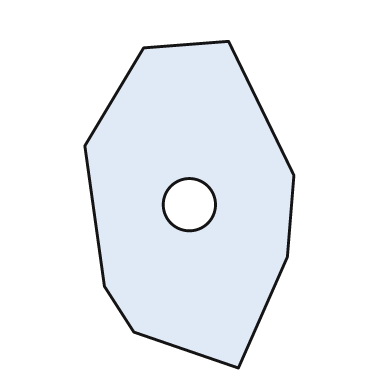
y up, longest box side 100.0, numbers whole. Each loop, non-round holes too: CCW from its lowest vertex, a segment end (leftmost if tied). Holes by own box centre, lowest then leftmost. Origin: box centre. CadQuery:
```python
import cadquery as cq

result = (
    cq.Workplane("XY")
    .moveTo(15.0, -50.0)
    .lineTo(30.0, -16.0)
    .lineTo(32.0, 9.0)
    .lineTo(12.0, 50.0)
    .lineTo(-14.0, 48.0)
    .lineTo(-32.0, 18.0)
    .lineTo(-26.0, -25.0)
    .lineTo(-17.0, -39.0)
    .close()
    .moveTo(0.0, 0.0)
    .circle(8.0)
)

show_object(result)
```